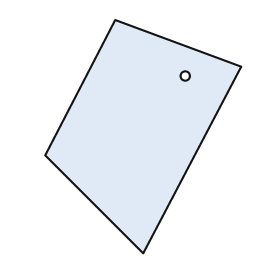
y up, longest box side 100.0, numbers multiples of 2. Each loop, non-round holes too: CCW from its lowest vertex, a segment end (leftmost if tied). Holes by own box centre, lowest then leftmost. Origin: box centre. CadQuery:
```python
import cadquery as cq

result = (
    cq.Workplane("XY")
    .moveTo(0.0, -50.0)
    .lineTo(42.0, 30.0)
    .lineTo(-12.0, 50.0)
    .lineTo(-42.0, -8.0)
    .close()
    .moveTo(18.0, 26.0)
    .circle(2.0)
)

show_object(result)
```